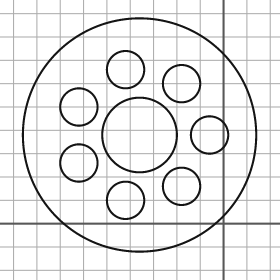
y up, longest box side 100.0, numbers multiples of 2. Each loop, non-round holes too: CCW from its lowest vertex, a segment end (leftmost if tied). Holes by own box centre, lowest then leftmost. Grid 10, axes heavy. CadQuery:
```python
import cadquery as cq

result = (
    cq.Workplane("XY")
    .moveTo(-36.0, 38.0)
    .circle(50.0)
    .moveTo(-42.0, 10.0)
    .circle(8.0)
    .moveTo(-18.0, 16.0)
    .circle(8.0)
    .moveTo(-62.0, 26.0)
    .circle(8.0)
    .moveTo(-36.0, 38.0)
    .circle(16.0)
    .moveTo(-6.0, 38.0)
    .circle(8.0)
    .moveTo(-62.0, 50.0)
    .circle(8.0)
    .moveTo(-18.0, 60.0)
    .circle(8.0)
    .moveTo(-42.0, 66.0)
    .circle(8.0)
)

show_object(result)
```